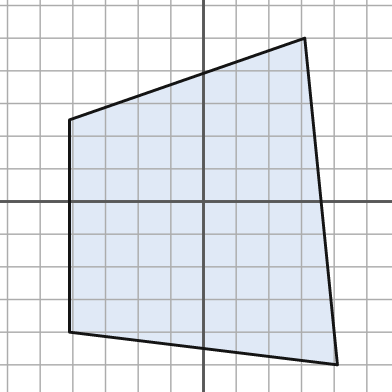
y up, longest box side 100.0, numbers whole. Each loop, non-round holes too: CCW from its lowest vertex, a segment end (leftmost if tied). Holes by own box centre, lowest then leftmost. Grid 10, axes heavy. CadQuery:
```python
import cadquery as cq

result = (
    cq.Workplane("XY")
    .moveTo(41.0, -50.0)
    .lineTo(31.0, 50.0)
    .lineTo(-41.0, 25.0)
    .lineTo(-41.0, -40.0)
    .close()
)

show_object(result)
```